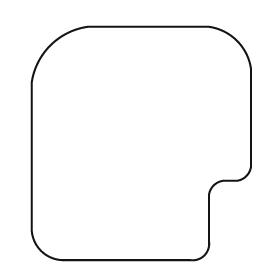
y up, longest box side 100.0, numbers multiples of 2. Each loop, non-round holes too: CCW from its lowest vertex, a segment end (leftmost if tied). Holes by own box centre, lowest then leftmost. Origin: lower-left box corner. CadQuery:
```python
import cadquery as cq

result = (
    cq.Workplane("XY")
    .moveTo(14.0, 0.0)
    .lineTo(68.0, 0.0)
    .threePointArc((74.0, 2.0), (76.0, 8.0))
    .lineTo(76.0, 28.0)
    .threePointArc((78.0, 32.0), (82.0, 34.0))
    .lineTo(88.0, 34.0)
    .threePointArc((92.0, 36.0), (94.0, 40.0))
    .lineTo(94.0, 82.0)
    .threePointArc((88.0, 94.0), (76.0, 100.0))
    .lineTo(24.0, 100.0)
    .threePointArc((8.0, 92.0), (0.0, 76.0))
    .lineTo(0.0, 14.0)
    .threePointArc((4.0, 4.0), (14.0, 0.0))
    .close()
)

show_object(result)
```